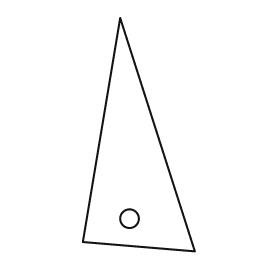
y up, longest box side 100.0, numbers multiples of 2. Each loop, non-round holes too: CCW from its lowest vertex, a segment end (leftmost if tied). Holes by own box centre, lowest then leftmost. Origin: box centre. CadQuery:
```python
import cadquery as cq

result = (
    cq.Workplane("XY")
    .moveTo(24.0, -50.0)
    .lineTo(-8.0, 50.0)
    .lineTo(-24.0, -46.0)
    .close()
    .moveTo(-4.0, -36.0)
    .circle(4.0)
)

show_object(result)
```